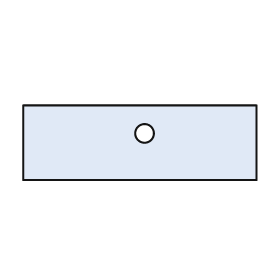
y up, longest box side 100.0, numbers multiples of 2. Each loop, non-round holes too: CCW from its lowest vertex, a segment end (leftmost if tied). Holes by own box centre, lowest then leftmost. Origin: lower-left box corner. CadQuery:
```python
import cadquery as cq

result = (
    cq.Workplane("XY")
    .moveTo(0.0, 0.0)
    .lineTo(100.0, 0.0)
    .lineTo(100.0, 32.0)
    .lineTo(0.0, 32.0)
    .close()
    .moveTo(52.0, 20.0)
    .circle(4.0)
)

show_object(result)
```